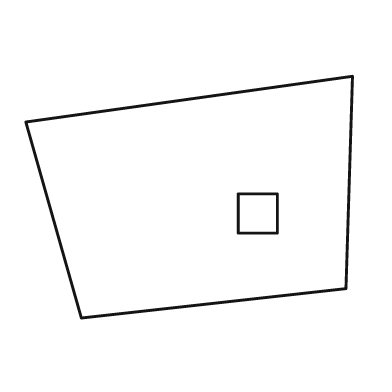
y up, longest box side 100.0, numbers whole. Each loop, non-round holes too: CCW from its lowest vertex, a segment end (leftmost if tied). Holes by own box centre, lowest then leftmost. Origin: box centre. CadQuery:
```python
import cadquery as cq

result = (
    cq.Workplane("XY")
    .moveTo(-33.0, -37.0)
    .lineTo(48.0, -28.0)
    .lineTo(50.0, 37.0)
    .lineTo(-50.0, 23.0)
    .close()
    .moveTo(15.0, -11.0)
    .lineTo(27.0, -11.0)
    .lineTo(27.0, 1.0)
    .lineTo(15.0, 1.0)
    .close()
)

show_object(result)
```